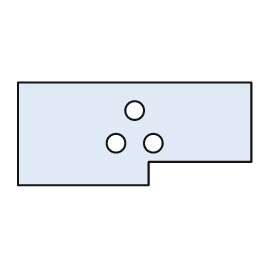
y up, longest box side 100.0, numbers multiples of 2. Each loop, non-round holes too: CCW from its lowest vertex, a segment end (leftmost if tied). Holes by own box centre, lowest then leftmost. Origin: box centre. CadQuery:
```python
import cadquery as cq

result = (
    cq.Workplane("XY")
    .moveTo(-50.0, -22.0)
    .lineTo(6.0, -22.0)
    .lineTo(6.0, -12.0)
    .lineTo(50.0, -12.0)
    .lineTo(50.0, 22.0)
    .lineTo(-50.0, 22.0)
    .close()
    .moveTo(-8.0, -4.0)
    .circle(4.0)
    .moveTo(8.0, -4.0)
    .circle(4.0)
    .moveTo(0.0, 10.0)
    .circle(4.0)
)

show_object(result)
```